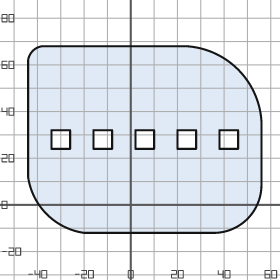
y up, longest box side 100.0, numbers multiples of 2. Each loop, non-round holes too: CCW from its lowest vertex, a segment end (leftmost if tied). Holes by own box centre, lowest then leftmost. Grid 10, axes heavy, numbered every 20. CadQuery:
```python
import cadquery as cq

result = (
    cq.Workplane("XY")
    .moveTo(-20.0, -12.0)
    .lineTo(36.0, -12.0)
    .threePointArc((50.0, -6.0), (56.0, 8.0))
    .lineTo(56.0, 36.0)
    .threePointArc((46.0, 58.0), (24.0, 68.0))
    .lineTo(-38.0, 68.0)
    .threePointArc((-42.0, 66.0), (-44.0, 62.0))
    .lineTo(-44.0, 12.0)
    .threePointArc((-36.0, -4.0), (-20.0, -12.0))
    .close()
    .moveTo(-34.0, 24.0)
    .lineTo(-26.0, 24.0)
    .lineTo(-26.0, 32.0)
    .lineTo(-34.0, 32.0)
    .close()
    .moveTo(-16.0, 24.0)
    .lineTo(-8.0, 24.0)
    .lineTo(-8.0, 32.0)
    .lineTo(-16.0, 32.0)
    .close()
    .moveTo(2.0, 24.0)
    .lineTo(10.0, 24.0)
    .lineTo(10.0, 32.0)
    .lineTo(2.0, 32.0)
    .close()
    .moveTo(20.0, 24.0)
    .lineTo(28.0, 24.0)
    .lineTo(28.0, 32.0)
    .lineTo(20.0, 32.0)
    .close()
    .moveTo(38.0, 24.0)
    .lineTo(46.0, 24.0)
    .lineTo(46.0, 32.0)
    .lineTo(38.0, 32.0)
    .close()
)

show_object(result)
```